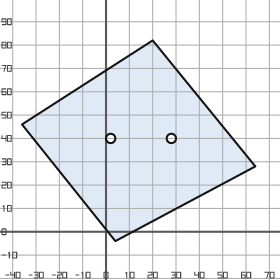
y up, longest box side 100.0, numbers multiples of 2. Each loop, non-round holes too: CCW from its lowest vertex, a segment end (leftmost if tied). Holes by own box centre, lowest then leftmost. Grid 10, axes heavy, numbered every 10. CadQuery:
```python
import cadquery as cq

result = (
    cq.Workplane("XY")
    .moveTo(4.0, -4.0)
    .lineTo(64.0, 28.0)
    .lineTo(20.0, 82.0)
    .lineTo(-36.0, 46.0)
    .close()
    .moveTo(2.0, 40.0)
    .circle(2.0)
    .moveTo(28.0, 40.0)
    .circle(2.0)
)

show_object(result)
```